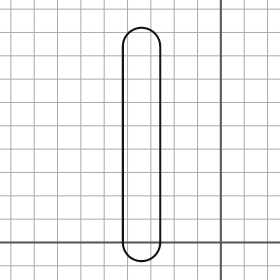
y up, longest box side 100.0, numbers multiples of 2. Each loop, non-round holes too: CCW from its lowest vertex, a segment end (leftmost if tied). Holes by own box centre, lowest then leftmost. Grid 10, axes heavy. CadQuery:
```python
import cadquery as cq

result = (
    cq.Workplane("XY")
    .moveTo(-42.0, 0.0)
    .threePointArc((-34.0, -8.0), (-26.0, 0.0))
    .lineTo(-26.0, 84.0)
    .threePointArc((-34.0, 92.0), (-42.0, 84.0))
    .close()
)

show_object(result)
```